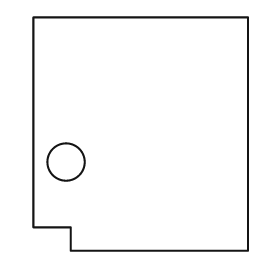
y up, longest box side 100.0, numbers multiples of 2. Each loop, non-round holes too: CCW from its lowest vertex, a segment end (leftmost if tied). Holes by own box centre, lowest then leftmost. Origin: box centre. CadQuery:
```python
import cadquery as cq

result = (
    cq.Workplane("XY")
    .moveTo(-30.0, -50.0)
    .lineTo(46.0, -50.0)
    .lineTo(46.0, 50.0)
    .lineTo(-46.0, 50.0)
    .lineTo(-46.0, -40.0)
    .lineTo(-30.0, -40.0)
    .close()
    .moveTo(-32.0, -12.0)
    .circle(8.0)
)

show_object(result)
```